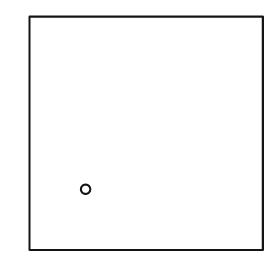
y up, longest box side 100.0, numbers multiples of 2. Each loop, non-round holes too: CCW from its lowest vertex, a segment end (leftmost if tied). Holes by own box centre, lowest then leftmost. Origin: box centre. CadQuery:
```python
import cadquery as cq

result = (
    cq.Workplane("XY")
    .moveTo(-50.0, -50.0)
    .lineTo(50.0, -50.0)
    .lineTo(50.0, 50.0)
    .lineTo(-50.0, 50.0)
    .close()
    .moveTo(-26.0, -24.0)
    .circle(2.0)
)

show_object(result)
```